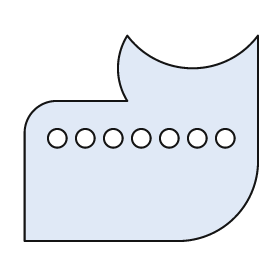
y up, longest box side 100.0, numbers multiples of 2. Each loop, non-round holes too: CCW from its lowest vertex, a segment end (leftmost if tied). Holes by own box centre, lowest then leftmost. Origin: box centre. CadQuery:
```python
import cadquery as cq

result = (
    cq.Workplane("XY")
    .moveTo(-50.0, -44.0)
    .lineTo(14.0, -44.0)
    .threePointArc((40.0, -34.0), (50.0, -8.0))
    .lineTo(50.0, 44.0)
    .threePointArc((22.0, 30.0), (-6.0, 44.0))
    .threePointArc((-10.0, 30.0), (-6.0, 16.0))
    .lineTo(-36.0, 16.0)
    .threePointArc((-46.0, 12.0), (-50.0, 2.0))
    .close()
    .moveTo(-36.0, 0.0)
    .circle(4.0)
    .moveTo(-24.0, 0.0)
    .circle(4.0)
    .moveTo(-12.0, 0.0)
    .circle(4.0)
    .moveTo(0.0, 0.0)
    .circle(4.0)
    .moveTo(12.0, 0.0)
    .circle(4.0)
    .moveTo(24.0, 0.0)
    .circle(4.0)
    .moveTo(36.0, 0.0)
    .circle(4.0)
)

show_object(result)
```